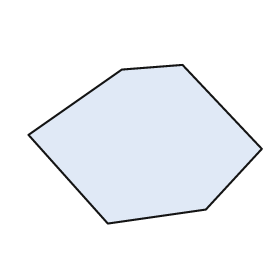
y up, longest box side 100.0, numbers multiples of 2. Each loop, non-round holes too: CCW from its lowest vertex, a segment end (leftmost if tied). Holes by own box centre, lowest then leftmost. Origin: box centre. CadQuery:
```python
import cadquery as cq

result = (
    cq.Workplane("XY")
    .moveTo(-16.0, -34.0)
    .lineTo(26.0, -28.0)
    .lineTo(50.0, -2.0)
    .lineTo(16.0, 34.0)
    .lineTo(-10.0, 32.0)
    .lineTo(-50.0, 4.0)
    .close()
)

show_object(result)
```